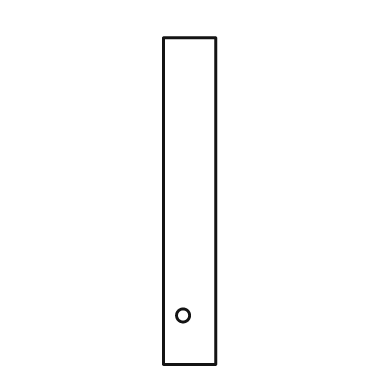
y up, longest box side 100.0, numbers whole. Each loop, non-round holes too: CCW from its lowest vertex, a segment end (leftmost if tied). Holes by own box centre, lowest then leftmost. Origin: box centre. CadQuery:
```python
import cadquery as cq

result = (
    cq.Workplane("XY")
    .moveTo(-8.0, -50.0)
    .lineTo(8.0, -50.0)
    .lineTo(8.0, 50.0)
    .lineTo(-8.0, 50.0)
    .close()
    .moveTo(-2.0, -35.0)
    .circle(2.0)
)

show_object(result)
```